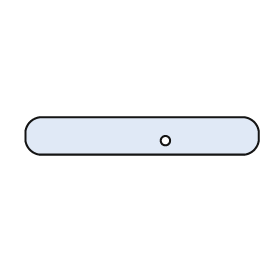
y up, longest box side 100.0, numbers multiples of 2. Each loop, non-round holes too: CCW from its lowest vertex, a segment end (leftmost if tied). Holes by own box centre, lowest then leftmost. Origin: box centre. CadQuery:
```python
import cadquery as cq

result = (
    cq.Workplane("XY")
    .moveTo(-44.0, -8.0)
    .lineTo(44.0, -8.0)
    .threePointArc((48.0, -6.0), (50.0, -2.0))
    .lineTo(50.0, 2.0)
    .threePointArc((48.0, 6.0), (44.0, 8.0))
    .lineTo(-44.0, 8.0)
    .threePointArc((-48.0, 6.0), (-50.0, 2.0))
    .lineTo(-50.0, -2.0)
    .threePointArc((-48.0, -6.0), (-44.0, -8.0))
    .close()
    .moveTo(10.0, -2.0)
    .circle(2.0)
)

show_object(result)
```